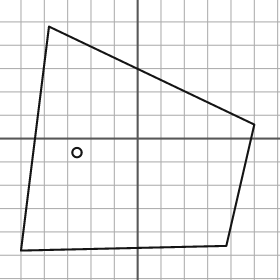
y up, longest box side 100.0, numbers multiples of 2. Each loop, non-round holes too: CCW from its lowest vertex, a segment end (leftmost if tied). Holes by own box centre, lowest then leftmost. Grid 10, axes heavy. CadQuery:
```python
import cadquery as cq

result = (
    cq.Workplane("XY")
    .moveTo(-50.0, -48.0)
    .lineTo(38.0, -46.0)
    .lineTo(50.0, 6.0)
    .lineTo(-38.0, 48.0)
    .close()
    .moveTo(-26.0, -6.0)
    .circle(2.0)
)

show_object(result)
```